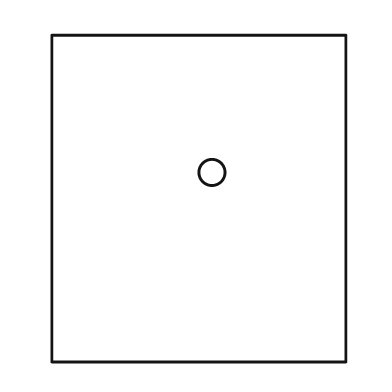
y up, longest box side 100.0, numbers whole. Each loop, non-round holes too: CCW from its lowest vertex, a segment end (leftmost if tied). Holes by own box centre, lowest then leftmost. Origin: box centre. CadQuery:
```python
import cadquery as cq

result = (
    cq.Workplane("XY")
    .moveTo(-45.0, -50.0)
    .lineTo(45.0, -50.0)
    .lineTo(45.0, 50.0)
    .lineTo(-45.0, 50.0)
    .close()
    .moveTo(4.0, 8.0)
    .circle(4.0)
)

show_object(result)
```